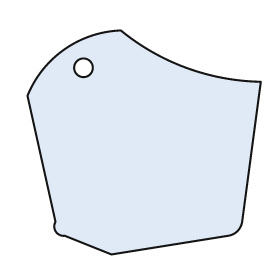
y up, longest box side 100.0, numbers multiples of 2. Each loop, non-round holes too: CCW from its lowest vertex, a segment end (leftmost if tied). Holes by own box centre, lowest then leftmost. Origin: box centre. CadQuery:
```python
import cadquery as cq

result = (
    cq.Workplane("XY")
    .moveTo(-14.0, -48.0)
    .lineTo(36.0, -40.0)
    .threePointArc((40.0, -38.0), (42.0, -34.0))
    .lineTo(50.0, 26.0)
    .threePointArc((18.0, 32.0), (-10.0, 48.0))
    .threePointArc((-34.0, 40.0), (-50.0, 20.0))
    .lineTo(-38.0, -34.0)
    .threePointArc((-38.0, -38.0), (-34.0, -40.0))
    .close()
    .moveTo(-26.0, 32.0)
    .circle(4.0)
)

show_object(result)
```